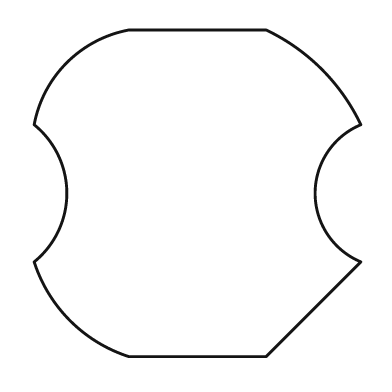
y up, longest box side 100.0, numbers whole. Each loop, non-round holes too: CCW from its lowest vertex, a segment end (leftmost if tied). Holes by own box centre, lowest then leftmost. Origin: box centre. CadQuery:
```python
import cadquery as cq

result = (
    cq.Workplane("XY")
    .moveTo(-21.0, -50.0)
    .lineTo(21.0, -50.0)
    .lineTo(50.0, -21.0)
    .threePointArc((36.0, 0.0), (50.0, 21.0))
    .threePointArc((38.0, 38.0), (21.0, 50.0))
    .lineTo(-21.0, 50.0)
    .threePointArc((-40.0, 40.0), (-50.0, 21.0))
    .threePointArc((-40.0, 0.0), (-50.0, -21.0))
    .threePointArc((-39.0, -39.0), (-21.0, -50.0))
    .close()
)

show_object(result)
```